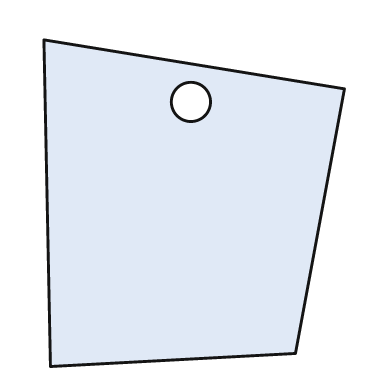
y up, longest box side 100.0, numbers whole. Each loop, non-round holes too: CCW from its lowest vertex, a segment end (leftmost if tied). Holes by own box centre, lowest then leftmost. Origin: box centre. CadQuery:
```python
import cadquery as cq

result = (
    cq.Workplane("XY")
    .moveTo(-44.0, -50.0)
    .lineTo(31.0, -46.0)
    .lineTo(46.0, 35.0)
    .lineTo(-46.0, 50.0)
    .close()
    .moveTo(-1.0, 31.0)
    .circle(6.0)
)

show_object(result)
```